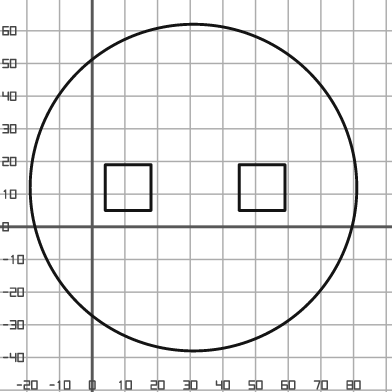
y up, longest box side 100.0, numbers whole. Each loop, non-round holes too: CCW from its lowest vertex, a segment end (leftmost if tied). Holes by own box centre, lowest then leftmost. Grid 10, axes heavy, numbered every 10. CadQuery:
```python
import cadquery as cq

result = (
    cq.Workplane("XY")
    .moveTo(31.0, 12.0)
    .circle(50.0)
    .moveTo(4.0, 5.0)
    .lineTo(18.0, 5.0)
    .lineTo(18.0, 19.0)
    .lineTo(4.0, 19.0)
    .close()
    .moveTo(45.0, 5.0)
    .lineTo(59.0, 5.0)
    .lineTo(59.0, 19.0)
    .lineTo(45.0, 19.0)
    .close()
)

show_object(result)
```